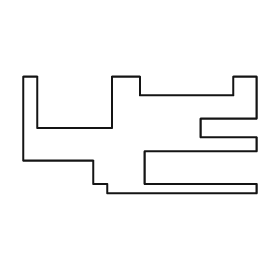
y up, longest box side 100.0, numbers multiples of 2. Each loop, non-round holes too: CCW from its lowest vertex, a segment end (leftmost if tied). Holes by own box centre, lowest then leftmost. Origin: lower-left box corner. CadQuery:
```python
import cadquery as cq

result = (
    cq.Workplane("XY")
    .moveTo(36.0, 0.0)
    .lineTo(100.0, 0.0)
    .lineTo(100.0, 4.0)
    .lineTo(52.0, 4.0)
    .lineTo(52.0, 18.0)
    .lineTo(100.0, 18.0)
    .lineTo(100.0, 24.0)
    .lineTo(76.0, 24.0)
    .lineTo(76.0, 32.0)
    .lineTo(100.0, 32.0)
    .lineTo(100.0, 50.0)
    .lineTo(90.0, 50.0)
    .lineTo(90.0, 42.0)
    .lineTo(50.0, 42.0)
    .lineTo(50.0, 50.0)
    .lineTo(38.0, 50.0)
    .lineTo(38.0, 28.0)
    .lineTo(6.0, 28.0)
    .lineTo(6.0, 50.0)
    .lineTo(0.0, 50.0)
    .lineTo(0.0, 14.0)
    .lineTo(30.0, 14.0)
    .lineTo(30.0, 4.0)
    .lineTo(36.0, 4.0)
    .close()
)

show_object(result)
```